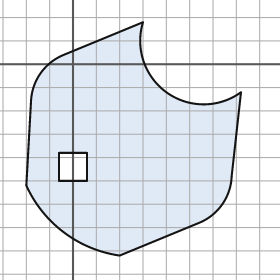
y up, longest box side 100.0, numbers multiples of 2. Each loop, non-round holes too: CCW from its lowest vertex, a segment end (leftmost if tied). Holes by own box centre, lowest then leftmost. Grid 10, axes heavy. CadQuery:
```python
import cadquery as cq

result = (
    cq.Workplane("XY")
    .moveTo(20.0, -82.0)
    .lineTo(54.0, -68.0)
    .threePointArc((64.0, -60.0), (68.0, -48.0))
    .lineTo(72.0, -12.0)
    .threePointArc((40.0, -12.0), (30.0, 18.0))
    .lineTo(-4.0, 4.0)
    .threePointArc((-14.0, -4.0), (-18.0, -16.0))
    .lineTo(-20.0, -52.0)
    .threePointArc((-4.0, -72.0), (20.0, -82.0))
    .close()
    .moveTo(-6.0, -50.0)
    .lineTo(6.0, -50.0)
    .lineTo(6.0, -38.0)
    .lineTo(-6.0, -38.0)
    .close()
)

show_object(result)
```